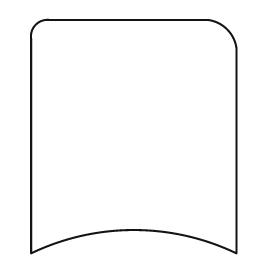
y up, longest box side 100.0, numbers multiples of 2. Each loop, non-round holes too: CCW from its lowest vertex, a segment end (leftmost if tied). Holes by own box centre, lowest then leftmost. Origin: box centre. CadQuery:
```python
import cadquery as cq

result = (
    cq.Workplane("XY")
    .moveTo(-44.0, -50.0)
    .threePointArc((0.0, -40.0), (44.0, -50.0))
    .lineTo(44.0, 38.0)
    .threePointArc((40.0, 46.0), (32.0, 50.0))
    .lineTo(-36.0, 50.0)
    .threePointArc((-42.0, 48.0), (-44.0, 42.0))
    .close()
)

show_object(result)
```